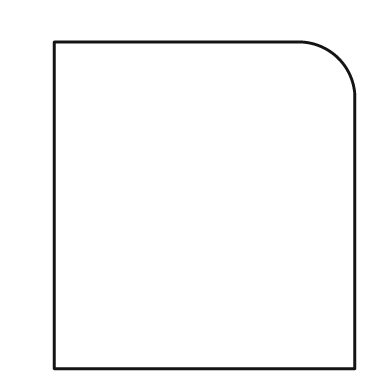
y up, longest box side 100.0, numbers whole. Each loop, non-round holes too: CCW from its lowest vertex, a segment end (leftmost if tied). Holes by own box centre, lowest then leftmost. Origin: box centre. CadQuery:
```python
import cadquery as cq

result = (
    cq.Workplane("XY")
    .moveTo(-46.0, -50.0)
    .lineTo(46.0, -50.0)
    .lineTo(46.0, 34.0)
    .threePointArc((41.0, 45.0), (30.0, 50.0))
    .lineTo(-46.0, 50.0)
    .close()
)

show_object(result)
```